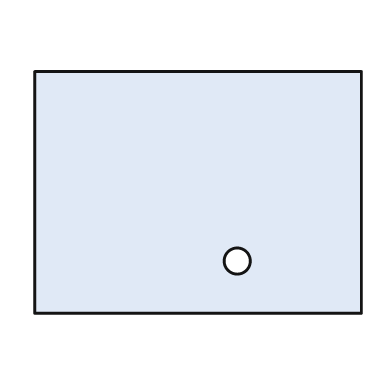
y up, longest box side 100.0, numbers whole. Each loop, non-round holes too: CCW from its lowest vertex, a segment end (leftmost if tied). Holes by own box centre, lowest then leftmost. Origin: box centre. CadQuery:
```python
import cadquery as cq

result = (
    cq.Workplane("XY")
    .moveTo(-50.0, -37.0)
    .lineTo(50.0, -37.0)
    .lineTo(50.0, 37.0)
    .lineTo(-50.0, 37.0)
    .close()
    .moveTo(12.0, -21.0)
    .circle(4.0)
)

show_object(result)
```